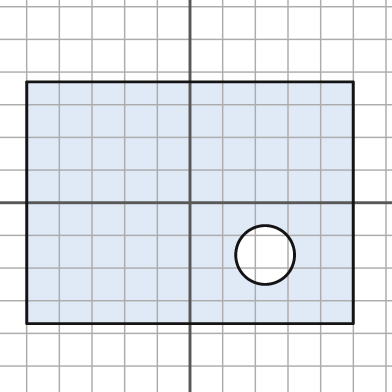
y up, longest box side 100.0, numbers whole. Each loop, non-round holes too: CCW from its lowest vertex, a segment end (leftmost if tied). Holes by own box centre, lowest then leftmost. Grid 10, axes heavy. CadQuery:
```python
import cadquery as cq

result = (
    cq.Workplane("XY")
    .moveTo(-50.0, -37.0)
    .lineTo(50.0, -37.0)
    .lineTo(50.0, 37.0)
    .lineTo(-50.0, 37.0)
    .close()
    .moveTo(23.0, -16.0)
    .circle(9.0)
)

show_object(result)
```